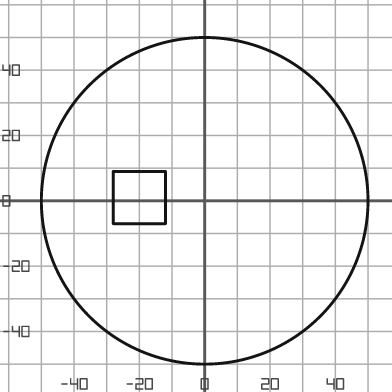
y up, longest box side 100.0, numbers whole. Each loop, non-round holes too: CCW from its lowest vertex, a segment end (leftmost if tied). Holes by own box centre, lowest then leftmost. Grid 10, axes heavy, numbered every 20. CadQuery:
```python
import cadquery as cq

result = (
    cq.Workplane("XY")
    .moveTo(0.0, 0.0)
    .circle(50.0)
    .moveTo(-28.0, -7.0)
    .lineTo(-12.0, -7.0)
    .lineTo(-12.0, 9.0)
    .lineTo(-28.0, 9.0)
    .close()
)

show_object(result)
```